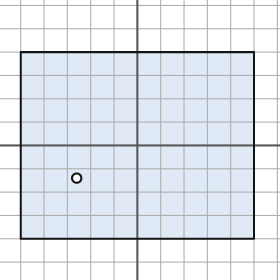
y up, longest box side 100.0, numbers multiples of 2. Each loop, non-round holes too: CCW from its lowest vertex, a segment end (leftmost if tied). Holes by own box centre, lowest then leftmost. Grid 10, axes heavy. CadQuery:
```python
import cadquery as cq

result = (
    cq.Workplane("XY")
    .moveTo(-50.0, -40.0)
    .lineTo(50.0, -40.0)
    .lineTo(50.0, 40.0)
    .lineTo(-50.0, 40.0)
    .close()
    .moveTo(-26.0, -14.0)
    .circle(2.0)
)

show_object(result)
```